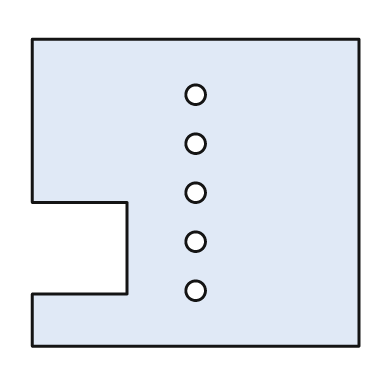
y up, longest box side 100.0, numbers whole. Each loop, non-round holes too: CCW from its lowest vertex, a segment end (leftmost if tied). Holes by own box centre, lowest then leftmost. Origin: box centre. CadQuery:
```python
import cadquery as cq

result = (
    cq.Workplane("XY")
    .moveTo(-50.0, -47.0)
    .lineTo(50.0, -47.0)
    .lineTo(50.0, 47.0)
    .lineTo(-50.0, 47.0)
    .lineTo(-50.0, -3.0)
    .lineTo(-21.0, -3.0)
    .lineTo(-21.0, -31.0)
    .lineTo(-50.0, -31.0)
    .close()
    .moveTo(0.0, -30.0)
    .circle(3.0)
    .moveTo(0.0, -15.0)
    .circle(3.0)
    .moveTo(0.0, 0.0)
    .circle(3.0)
    .moveTo(0.0, 15.0)
    .circle(3.0)
    .moveTo(0.0, 30.0)
    .circle(3.0)
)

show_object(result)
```